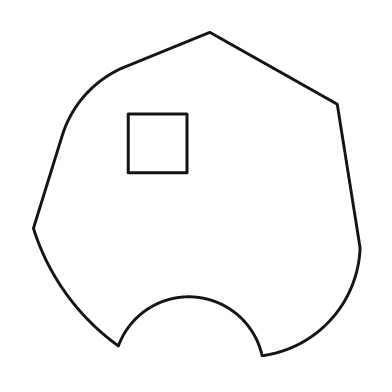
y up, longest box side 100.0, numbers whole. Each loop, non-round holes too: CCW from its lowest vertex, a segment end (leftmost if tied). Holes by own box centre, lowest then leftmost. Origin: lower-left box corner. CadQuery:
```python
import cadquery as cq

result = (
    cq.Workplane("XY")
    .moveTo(70.0, 0.0)
    .threePointArc((91.0, 11.0), (100.0, 33.0))
    .lineTo(93.0, 77.0)
    .lineTo(54.0, 99.0)
    .lineTo(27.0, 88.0)
    .threePointArc((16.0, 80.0), (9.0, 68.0))
    .lineTo(0.0, 39.0)
    .threePointArc((10.0, 19.0), (26.0, 3.0))
    .threePointArc((49.0, 18.0), (70.0, 0.0))
    .close()
    .moveTo(29.0, 56.0)
    .lineTo(47.0, 56.0)
    .lineTo(47.0, 74.0)
    .lineTo(29.0, 74.0)
    .close()
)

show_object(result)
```